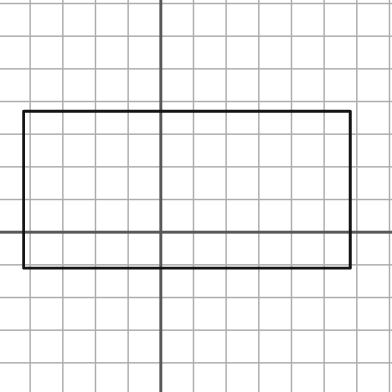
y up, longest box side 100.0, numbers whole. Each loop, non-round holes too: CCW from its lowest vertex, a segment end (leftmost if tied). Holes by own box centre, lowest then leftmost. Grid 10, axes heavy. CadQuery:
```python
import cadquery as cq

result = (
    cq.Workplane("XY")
    .moveTo(-42.0, -11.0)
    .lineTo(58.0, -11.0)
    .lineTo(58.0, 37.0)
    .lineTo(-42.0, 37.0)
    .close()
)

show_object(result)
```